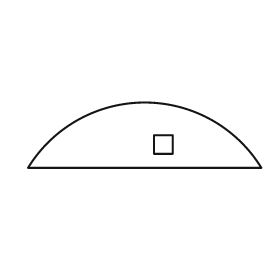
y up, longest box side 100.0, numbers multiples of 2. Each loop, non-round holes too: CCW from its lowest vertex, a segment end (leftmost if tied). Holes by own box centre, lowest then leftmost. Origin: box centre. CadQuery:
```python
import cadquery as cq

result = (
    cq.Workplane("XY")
    .moveTo(-50.0, -14.0)
    .lineTo(50.0, -14.0)
    .threePointArc((0.0, 14.0), (-50.0, -14.0))
    .close()
    .moveTo(4.0, -8.0)
    .lineTo(12.0, -8.0)
    .lineTo(12.0, 0.0)
    .lineTo(4.0, 0.0)
    .close()
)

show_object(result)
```